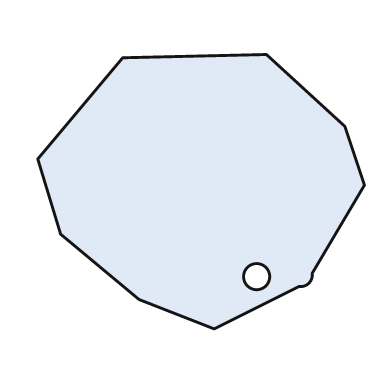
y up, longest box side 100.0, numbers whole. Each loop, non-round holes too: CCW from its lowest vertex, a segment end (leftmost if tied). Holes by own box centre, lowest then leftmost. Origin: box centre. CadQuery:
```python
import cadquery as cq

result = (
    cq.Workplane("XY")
    .moveTo(4.0, -42.0)
    .lineTo(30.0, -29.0)
    .threePointArc((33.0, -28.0), (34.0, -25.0))
    .lineTo(50.0, 2.0)
    .lineTo(44.0, 20.0)
    .lineTo(20.0, 42.0)
    .lineTo(-24.0, 41.0)
    .lineTo(-50.0, 10.0)
    .lineTo(-43.0, -13.0)
    .lineTo(-19.0, -33.0)
    .close()
    .moveTo(17.0, -26.0)
    .circle(4.0)
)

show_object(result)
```